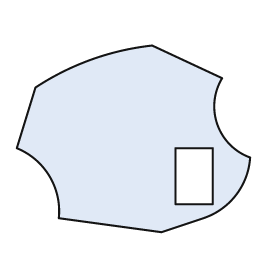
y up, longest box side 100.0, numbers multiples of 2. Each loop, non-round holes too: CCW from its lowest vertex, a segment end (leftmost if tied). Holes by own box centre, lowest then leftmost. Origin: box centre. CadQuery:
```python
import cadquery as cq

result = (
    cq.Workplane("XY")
    .moveTo(12.0, -40.0)
    .lineTo(30.0, -34.0)
    .threePointArc((44.0, -24.0), (50.0, -8.0))
    .threePointArc((36.0, 6.0), (38.0, 26.0))
    .lineTo(8.0, 40.0)
    .threePointArc((-18.0, 34.0), (-42.0, 22.0))
    .lineTo(-50.0, -4.0)
    .threePointArc((-36.0, -16.0), (-32.0, -34.0))
    .close()
    .moveTo(18.0, -28.0)
    .lineTo(34.0, -28.0)
    .lineTo(34.0, -4.0)
    .lineTo(18.0, -4.0)
    .close()
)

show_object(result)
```